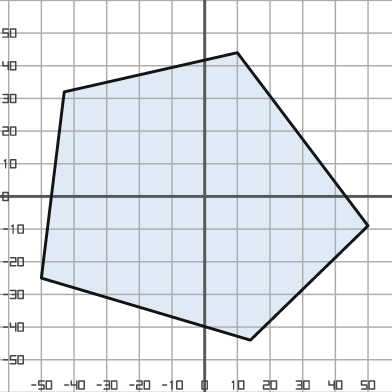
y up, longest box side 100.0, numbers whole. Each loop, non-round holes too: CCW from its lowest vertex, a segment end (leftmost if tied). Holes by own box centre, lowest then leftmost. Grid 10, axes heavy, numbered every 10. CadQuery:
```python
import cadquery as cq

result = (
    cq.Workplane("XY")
    .moveTo(14.0, -44.0)
    .lineTo(50.0, -9.0)
    .lineTo(10.0, 44.0)
    .lineTo(-43.0, 32.0)
    .lineTo(-50.0, -25.0)
    .close()
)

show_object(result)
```